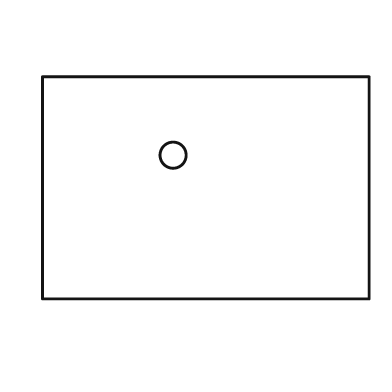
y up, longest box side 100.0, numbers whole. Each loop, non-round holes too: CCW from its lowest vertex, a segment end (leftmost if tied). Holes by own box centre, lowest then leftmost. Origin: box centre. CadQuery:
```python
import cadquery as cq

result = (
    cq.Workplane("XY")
    .moveTo(-50.0, -34.0)
    .lineTo(50.0, -34.0)
    .lineTo(50.0, 34.0)
    .lineTo(-50.0, 34.0)
    .close()
    .moveTo(-10.0, 10.0)
    .circle(4.0)
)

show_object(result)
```